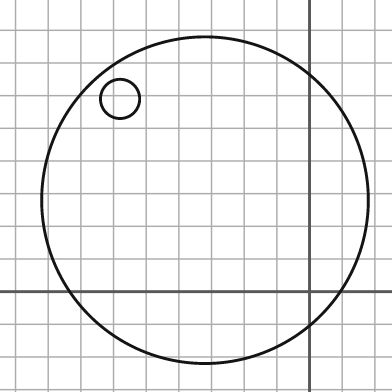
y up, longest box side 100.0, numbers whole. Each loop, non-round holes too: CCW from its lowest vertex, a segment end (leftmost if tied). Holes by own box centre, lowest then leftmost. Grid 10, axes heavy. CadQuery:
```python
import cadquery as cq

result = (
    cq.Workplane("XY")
    .moveTo(-32.0, 28.0)
    .circle(50.0)
    .moveTo(-58.0, 59.0)
    .circle(6.0)
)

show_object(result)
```